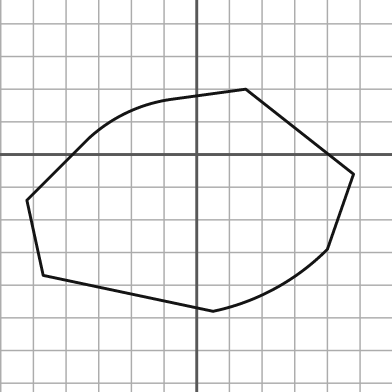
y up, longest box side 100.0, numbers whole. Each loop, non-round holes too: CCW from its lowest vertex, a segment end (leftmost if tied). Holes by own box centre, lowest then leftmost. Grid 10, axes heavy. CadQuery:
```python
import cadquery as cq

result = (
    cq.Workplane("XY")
    .moveTo(5.0, -48.0)
    .threePointArc((24.0, -41.0), (40.0, -29.0))
    .lineTo(48.0, -6.0)
    .lineTo(15.0, 20.0)
    .lineTo(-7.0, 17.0)
    .threePointArc((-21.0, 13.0), (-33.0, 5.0))
    .lineTo(-52.0, -14.0)
    .lineTo(-47.0, -37.0)
    .close()
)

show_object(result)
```